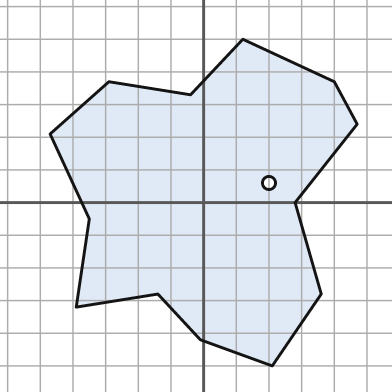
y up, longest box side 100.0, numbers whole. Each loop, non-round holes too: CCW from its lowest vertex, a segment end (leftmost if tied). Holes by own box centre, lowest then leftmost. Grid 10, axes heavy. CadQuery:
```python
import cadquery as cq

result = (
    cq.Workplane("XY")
    .moveTo(21.0, -50.0)
    .lineTo(36.0, -28.0)
    .lineTo(28.0, 0.0)
    .lineTo(47.0, 24.0)
    .lineTo(40.0, 37.0)
    .lineTo(12.0, 50.0)
    .lineTo(-4.0, 33.0)
    .lineTo(-29.0, 37.0)
    .lineTo(-47.0, 21.0)
    .lineTo(-35.0, -5.0)
    .lineTo(-39.0, -32.0)
    .lineTo(-14.0, -28.0)
    .lineTo(-1.0, -42.0)
    .close()
    .moveTo(20.0, 6.0)
    .circle(2.0)
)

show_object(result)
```